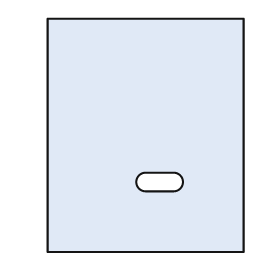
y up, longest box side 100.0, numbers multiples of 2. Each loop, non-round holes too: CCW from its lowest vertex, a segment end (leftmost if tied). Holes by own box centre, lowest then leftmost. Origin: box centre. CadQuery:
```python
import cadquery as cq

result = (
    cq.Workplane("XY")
    .moveTo(-42.0, -50.0)
    .lineTo(42.0, -50.0)
    .lineTo(42.0, 50.0)
    .lineTo(-42.0, 50.0)
    .close()
    .moveTo(0.0, -24.0)
    .lineTo(12.0, -24.0)
    .threePointArc((16.0, -20.0), (12.0, -16.0))
    .lineTo(0.0, -16.0)
    .threePointArc((-4.0, -20.0), (0.0, -24.0))
    .close()
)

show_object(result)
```